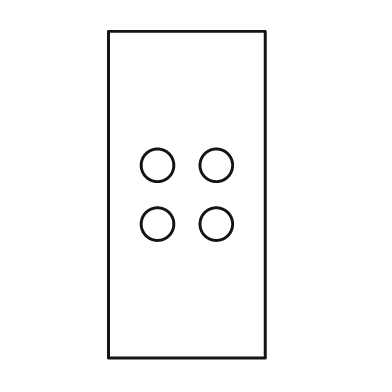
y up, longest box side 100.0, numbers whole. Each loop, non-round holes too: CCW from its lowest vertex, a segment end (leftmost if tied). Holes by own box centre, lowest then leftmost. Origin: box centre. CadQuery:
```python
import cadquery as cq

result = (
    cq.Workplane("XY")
    .moveTo(-24.0, -50.0)
    .lineTo(24.0, -50.0)
    .lineTo(24.0, 50.0)
    .lineTo(-24.0, 50.0)
    .close()
    .moveTo(-9.0, -9.0)
    .circle(5.0)
    .moveTo(9.0, -9.0)
    .circle(5.0)
    .moveTo(-9.0, 9.0)
    .circle(5.0)
    .moveTo(9.0, 9.0)
    .circle(5.0)
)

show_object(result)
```